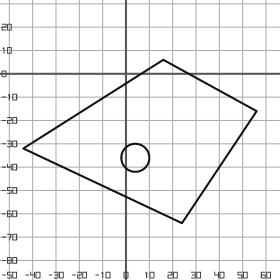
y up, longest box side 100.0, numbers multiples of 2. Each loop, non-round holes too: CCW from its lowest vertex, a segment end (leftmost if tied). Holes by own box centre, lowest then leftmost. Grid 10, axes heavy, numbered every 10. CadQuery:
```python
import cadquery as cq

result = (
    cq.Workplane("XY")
    .moveTo(24.0, -64.0)
    .lineTo(56.0, -16.0)
    .lineTo(16.0, 6.0)
    .lineTo(-44.0, -32.0)
    .close()
    .moveTo(4.0, -36.0)
    .circle(6.0)
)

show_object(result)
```